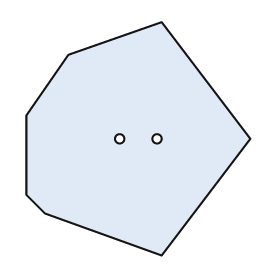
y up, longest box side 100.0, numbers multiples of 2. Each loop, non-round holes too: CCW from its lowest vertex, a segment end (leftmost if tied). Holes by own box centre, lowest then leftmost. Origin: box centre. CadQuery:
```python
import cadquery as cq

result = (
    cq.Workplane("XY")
    .moveTo(10.0, -50.0)
    .lineTo(48.0, 0.0)
    .lineTo(10.0, 50.0)
    .lineTo(-30.0, 36.0)
    .lineTo(-48.0, 10.0)
    .lineTo(-48.0, -24.0)
    .lineTo(-40.0, -32.0)
    .close()
    .moveTo(-8.0, 0.0)
    .circle(2.0)
    .moveTo(8.0, 0.0)
    .circle(2.0)
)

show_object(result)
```